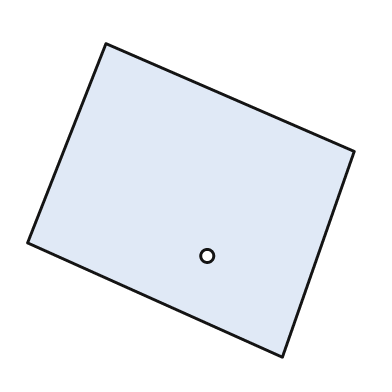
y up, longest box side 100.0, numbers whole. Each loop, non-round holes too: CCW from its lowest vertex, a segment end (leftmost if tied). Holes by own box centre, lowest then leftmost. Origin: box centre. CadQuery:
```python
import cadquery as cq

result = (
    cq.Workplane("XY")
    .moveTo(28.0, -48.0)
    .lineTo(50.0, 15.0)
    .lineTo(-26.0, 48.0)
    .lineTo(-50.0, -13.0)
    .close()
    .moveTo(5.0, -17.0)
    .circle(2.0)
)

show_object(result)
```